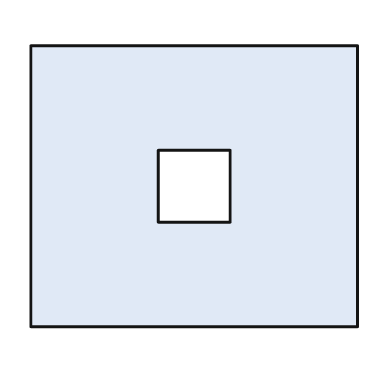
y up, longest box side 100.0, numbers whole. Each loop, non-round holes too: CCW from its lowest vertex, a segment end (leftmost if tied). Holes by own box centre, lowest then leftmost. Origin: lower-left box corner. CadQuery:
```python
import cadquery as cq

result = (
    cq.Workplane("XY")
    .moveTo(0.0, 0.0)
    .lineTo(100.0, 0.0)
    .lineTo(100.0, 86.0)
    .lineTo(0.0, 86.0)
    .close()
    .moveTo(39.0, 32.0)
    .lineTo(61.0, 32.0)
    .lineTo(61.0, 54.0)
    .lineTo(39.0, 54.0)
    .close()
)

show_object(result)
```